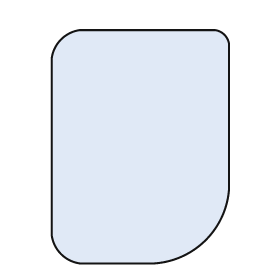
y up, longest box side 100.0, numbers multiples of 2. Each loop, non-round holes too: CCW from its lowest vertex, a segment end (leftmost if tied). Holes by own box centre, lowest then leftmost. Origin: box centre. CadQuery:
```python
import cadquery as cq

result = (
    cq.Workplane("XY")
    .moveTo(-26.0, -50.0)
    .lineTo(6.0, -50.0)
    .threePointArc((28.0, -40.0), (38.0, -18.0))
    .lineTo(38.0, 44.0)
    .threePointArc((36.0, 48.0), (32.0, 50.0))
    .lineTo(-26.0, 50.0)
    .threePointArc((-34.0, 46.0), (-38.0, 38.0))
    .lineTo(-38.0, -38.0)
    .threePointArc((-34.0, -46.0), (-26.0, -50.0))
    .close()
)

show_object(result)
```